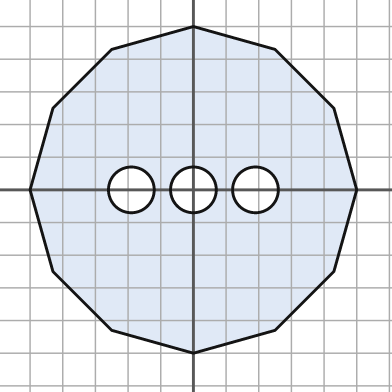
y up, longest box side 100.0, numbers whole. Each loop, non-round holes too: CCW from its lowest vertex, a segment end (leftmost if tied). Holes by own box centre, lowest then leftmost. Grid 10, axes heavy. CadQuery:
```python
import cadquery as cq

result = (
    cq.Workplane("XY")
    .moveTo(0.0, -50.0)
    .lineTo(25.0, -43.0)
    .lineTo(43.0, -25.0)
    .lineTo(50.0, 0.0)
    .lineTo(43.0, 25.0)
    .lineTo(25.0, 43.0)
    .lineTo(0.0, 50.0)
    .lineTo(-25.0, 43.0)
    .lineTo(-43.0, 25.0)
    .lineTo(-50.0, 0.0)
    .lineTo(-43.0, -25.0)
    .lineTo(-25.0, -43.0)
    .close()
    .moveTo(-19.0, 0.0)
    .circle(7.0)
    .moveTo(0.0, 0.0)
    .circle(7.0)
    .moveTo(19.0, 0.0)
    .circle(7.0)
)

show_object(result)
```